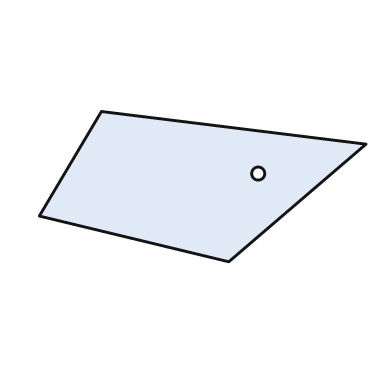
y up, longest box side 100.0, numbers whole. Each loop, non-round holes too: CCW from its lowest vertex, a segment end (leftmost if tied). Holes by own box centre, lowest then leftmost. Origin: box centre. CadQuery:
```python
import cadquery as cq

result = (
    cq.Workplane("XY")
    .moveTo(8.0, -23.0)
    .lineTo(50.0, 13.0)
    .lineTo(-31.0, 23.0)
    .lineTo(-50.0, -9.0)
    .close()
    .moveTo(17.0, 4.0)
    .circle(2.0)
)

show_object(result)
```